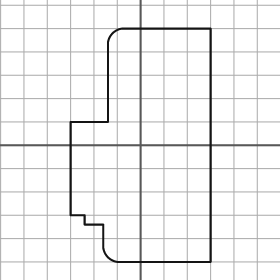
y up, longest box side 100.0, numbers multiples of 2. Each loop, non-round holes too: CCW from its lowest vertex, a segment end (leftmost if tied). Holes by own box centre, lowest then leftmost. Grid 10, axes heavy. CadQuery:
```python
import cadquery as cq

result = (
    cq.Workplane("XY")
    .moveTo(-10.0, -50.0)
    .lineTo(30.0, -50.0)
    .lineTo(30.0, 50.0)
    .lineTo(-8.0, 50.0)
    .threePointArc((-12.0, 48.0), (-14.0, 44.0))
    .lineTo(-14.0, 10.0)
    .lineTo(-30.0, 10.0)
    .lineTo(-30.0, -30.0)
    .lineTo(-24.0, -30.0)
    .lineTo(-24.0, -34.0)
    .lineTo(-16.0, -34.0)
    .lineTo(-16.0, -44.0)
    .threePointArc((-14.0, -48.0), (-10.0, -50.0))
    .close()
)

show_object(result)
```